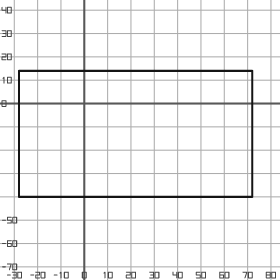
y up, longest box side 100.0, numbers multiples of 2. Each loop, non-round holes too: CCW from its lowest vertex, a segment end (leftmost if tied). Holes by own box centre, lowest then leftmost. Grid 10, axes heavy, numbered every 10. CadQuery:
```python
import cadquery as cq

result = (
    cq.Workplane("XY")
    .moveTo(-28.0, -40.0)
    .lineTo(72.0, -40.0)
    .lineTo(72.0, 14.0)
    .lineTo(-28.0, 14.0)
    .close()
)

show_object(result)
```